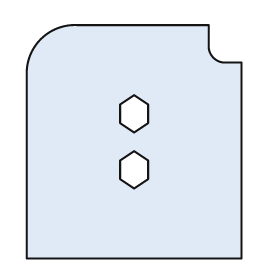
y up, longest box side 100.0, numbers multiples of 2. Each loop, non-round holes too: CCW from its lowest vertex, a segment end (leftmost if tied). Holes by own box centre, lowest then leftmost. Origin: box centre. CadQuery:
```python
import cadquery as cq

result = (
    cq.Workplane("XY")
    .moveTo(-46.0, -50.0)
    .lineTo(46.0, -50.0)
    .lineTo(46.0, 34.0)
    .lineTo(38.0, 34.0)
    .threePointArc((34.0, 36.0), (32.0, 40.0))
    .lineTo(32.0, 50.0)
    .lineTo(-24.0, 50.0)
    .threePointArc((-40.0, 44.0), (-46.0, 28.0))
    .close()
    .moveTo(0.0, -20.0)
    .lineTo(6.0, -16.0)
    .lineTo(6.0, -8.0)
    .lineTo(0.0, -4.0)
    .lineTo(-6.0, -8.0)
    .lineTo(-6.0, -16.0)
    .close()
    .moveTo(0.0, 4.0)
    .lineTo(6.0, 8.0)
    .lineTo(6.0, 16.0)
    .lineTo(0.0, 20.0)
    .lineTo(-6.0, 16.0)
    .lineTo(-6.0, 8.0)
    .close()
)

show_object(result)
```